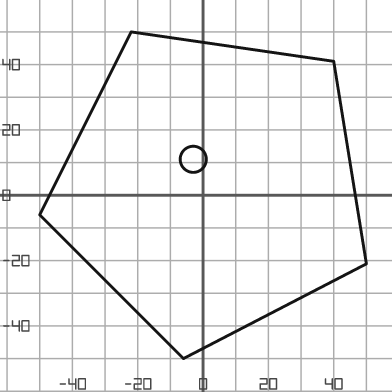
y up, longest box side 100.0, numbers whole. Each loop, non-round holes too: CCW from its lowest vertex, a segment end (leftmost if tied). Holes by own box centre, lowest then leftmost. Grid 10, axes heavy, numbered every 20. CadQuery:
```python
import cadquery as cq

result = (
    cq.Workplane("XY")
    .moveTo(-6.0, -50.0)
    .lineTo(50.0, -21.0)
    .lineTo(40.0, 41.0)
    .lineTo(-22.0, 50.0)
    .lineTo(-50.0, -6.0)
    .close()
    .moveTo(-3.0, 11.0)
    .circle(4.0)
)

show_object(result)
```